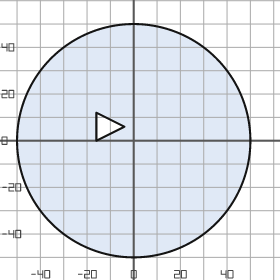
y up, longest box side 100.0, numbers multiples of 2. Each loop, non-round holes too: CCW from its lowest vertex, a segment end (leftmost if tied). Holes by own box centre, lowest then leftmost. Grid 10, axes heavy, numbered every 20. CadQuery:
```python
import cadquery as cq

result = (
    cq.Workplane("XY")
    .moveTo(0.0, 0.0)
    .circle(50.0)
    .moveTo(-16.0, 0.0)
    .lineTo(-4.0, 6.0)
    .lineTo(-16.0, 12.0)
    .close()
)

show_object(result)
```